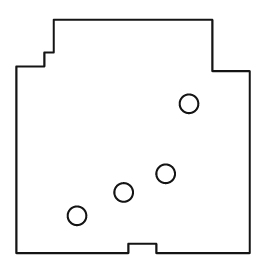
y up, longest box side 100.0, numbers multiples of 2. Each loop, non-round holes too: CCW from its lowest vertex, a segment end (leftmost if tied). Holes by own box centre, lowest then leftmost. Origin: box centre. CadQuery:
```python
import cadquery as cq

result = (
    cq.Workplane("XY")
    .moveTo(-50.0, -50.0)
    .lineTo(-2.0, -50.0)
    .lineTo(-2.0, -46.0)
    .lineTo(10.0, -46.0)
    .lineTo(10.0, -50.0)
    .lineTo(50.0, -50.0)
    .lineTo(50.0, 28.0)
    .lineTo(34.0, 28.0)
    .lineTo(34.0, 50.0)
    .lineTo(-34.0, 50.0)
    .lineTo(-34.0, 36.0)
    .lineTo(-38.0, 36.0)
    .lineTo(-38.0, 30.0)
    .lineTo(-50.0, 30.0)
    .close()
    .moveTo(-24.0, -34.0)
    .circle(4.0)
    .moveTo(-4.0, -24.0)
    .circle(4.0)
    .moveTo(14.0, -16.0)
    .circle(4.0)
    .moveTo(24.0, 14.0)
    .circle(4.0)
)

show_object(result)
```